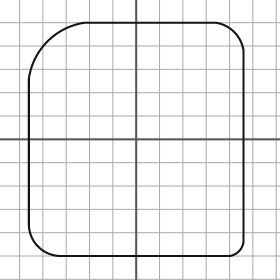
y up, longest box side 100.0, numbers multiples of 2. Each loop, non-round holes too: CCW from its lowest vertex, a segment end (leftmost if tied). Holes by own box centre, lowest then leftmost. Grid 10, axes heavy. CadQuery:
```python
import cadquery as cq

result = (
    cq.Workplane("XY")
    .moveTo(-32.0, -50.0)
    .lineTo(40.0, -50.0)
    .threePointArc((44.0, -48.0), (46.0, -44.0))
    .lineTo(46.0, 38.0)
    .threePointArc((42.0, 46.0), (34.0, 50.0))
    .lineTo(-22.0, 50.0)
    .threePointArc((-38.0, 42.0), (-46.0, 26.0))
    .lineTo(-46.0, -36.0)
    .threePointArc((-42.0, -46.0), (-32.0, -50.0))
    .close()
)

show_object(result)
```